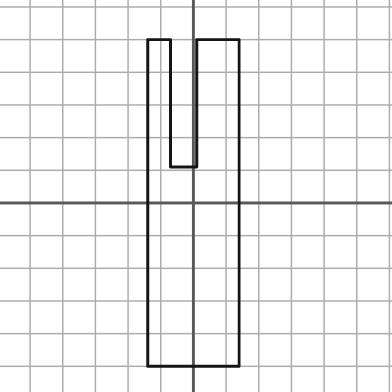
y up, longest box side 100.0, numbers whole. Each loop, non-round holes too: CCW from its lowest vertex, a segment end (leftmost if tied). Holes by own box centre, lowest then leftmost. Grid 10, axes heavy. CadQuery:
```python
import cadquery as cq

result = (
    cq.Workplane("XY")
    .moveTo(-14.0, -50.0)
    .lineTo(14.0, -50.0)
    .lineTo(14.0, 50.0)
    .lineTo(1.0, 50.0)
    .lineTo(1.0, 11.0)
    .lineTo(-7.0, 11.0)
    .lineTo(-7.0, 50.0)
    .lineTo(-14.0, 50.0)
    .close()
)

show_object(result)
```